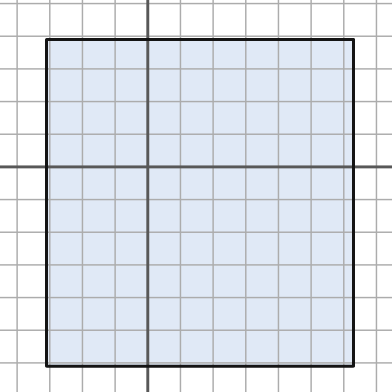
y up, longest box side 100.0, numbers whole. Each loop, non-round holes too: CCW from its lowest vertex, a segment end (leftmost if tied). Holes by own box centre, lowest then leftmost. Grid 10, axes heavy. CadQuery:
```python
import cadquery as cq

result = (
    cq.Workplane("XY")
    .moveTo(-31.0, -61.0)
    .lineTo(63.0, -61.0)
    .lineTo(63.0, 39.0)
    .lineTo(-31.0, 39.0)
    .close()
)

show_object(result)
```